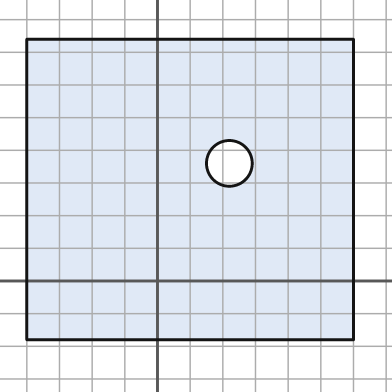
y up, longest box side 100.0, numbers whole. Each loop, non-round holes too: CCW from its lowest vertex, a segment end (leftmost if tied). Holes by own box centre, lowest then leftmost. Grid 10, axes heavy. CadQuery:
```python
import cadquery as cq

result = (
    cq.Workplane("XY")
    .moveTo(-40.0, -18.0)
    .lineTo(60.0, -18.0)
    .lineTo(60.0, 74.0)
    .lineTo(-40.0, 74.0)
    .close()
    .moveTo(22.0, 36.0)
    .circle(7.0)
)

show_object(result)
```